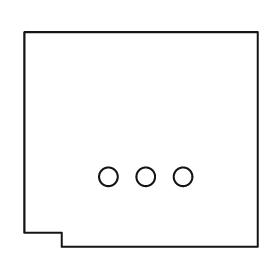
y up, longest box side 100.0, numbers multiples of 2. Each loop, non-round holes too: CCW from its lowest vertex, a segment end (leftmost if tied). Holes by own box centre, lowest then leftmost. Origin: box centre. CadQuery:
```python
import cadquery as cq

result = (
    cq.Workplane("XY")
    .moveTo(-34.0, -46.0)
    .lineTo(50.0, -46.0)
    .lineTo(50.0, 46.0)
    .lineTo(-50.0, 46.0)
    .lineTo(-50.0, -40.0)
    .lineTo(-34.0, -40.0)
    .close()
    .moveTo(-14.0, -16.0)
    .circle(4.0)
    .moveTo(2.0, -16.0)
    .circle(4.0)
    .moveTo(18.0, -16.0)
    .circle(4.0)
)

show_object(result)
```